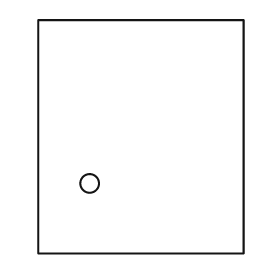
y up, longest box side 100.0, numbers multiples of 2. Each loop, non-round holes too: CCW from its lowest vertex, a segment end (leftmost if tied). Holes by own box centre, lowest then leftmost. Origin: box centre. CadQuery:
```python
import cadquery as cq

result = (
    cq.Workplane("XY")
    .moveTo(-44.0, -50.0)
    .lineTo(44.0, -50.0)
    .lineTo(44.0, 50.0)
    .lineTo(-44.0, 50.0)
    .close()
    .moveTo(-22.0, -20.0)
    .circle(4.0)
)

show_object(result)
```